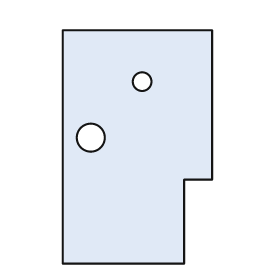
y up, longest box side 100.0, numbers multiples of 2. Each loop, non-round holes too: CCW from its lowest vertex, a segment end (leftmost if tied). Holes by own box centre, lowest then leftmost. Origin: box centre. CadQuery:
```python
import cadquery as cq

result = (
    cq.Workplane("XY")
    .moveTo(-32.0, -50.0)
    .lineTo(20.0, -50.0)
    .lineTo(20.0, -14.0)
    .lineTo(32.0, -14.0)
    .lineTo(32.0, 50.0)
    .lineTo(-32.0, 50.0)
    .close()
    .moveTo(-20.0, 4.0)
    .circle(6.0)
    .moveTo(2.0, 28.0)
    .circle(4.0)
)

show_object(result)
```